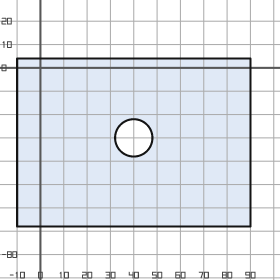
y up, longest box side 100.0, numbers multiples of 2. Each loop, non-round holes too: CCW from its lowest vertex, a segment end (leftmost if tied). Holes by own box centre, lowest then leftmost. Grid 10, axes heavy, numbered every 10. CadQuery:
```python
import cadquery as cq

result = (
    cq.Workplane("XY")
    .moveTo(-10.0, -68.0)
    .lineTo(90.0, -68.0)
    .lineTo(90.0, 4.0)
    .lineTo(-10.0, 4.0)
    .close()
    .moveTo(40.0, -30.0)
    .circle(8.0)
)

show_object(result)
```